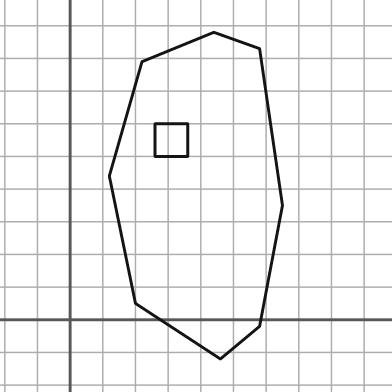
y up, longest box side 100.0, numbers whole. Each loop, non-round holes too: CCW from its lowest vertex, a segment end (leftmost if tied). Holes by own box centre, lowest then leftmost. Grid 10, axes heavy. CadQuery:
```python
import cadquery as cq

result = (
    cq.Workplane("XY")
    .moveTo(46.0, -12.0)
    .lineTo(58.0, -2.0)
    .lineTo(65.0, 35.0)
    .lineTo(58.0, 83.0)
    .lineTo(44.0, 88.0)
    .lineTo(22.0, 79.0)
    .lineTo(12.0, 44.0)
    .lineTo(20.0, 5.0)
    .close()
    .moveTo(26.0, 50.0)
    .lineTo(36.0, 50.0)
    .lineTo(36.0, 60.0)
    .lineTo(26.0, 60.0)
    .close()
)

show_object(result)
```